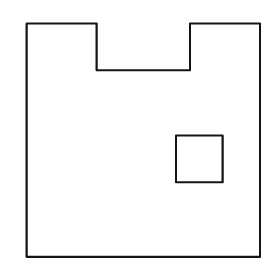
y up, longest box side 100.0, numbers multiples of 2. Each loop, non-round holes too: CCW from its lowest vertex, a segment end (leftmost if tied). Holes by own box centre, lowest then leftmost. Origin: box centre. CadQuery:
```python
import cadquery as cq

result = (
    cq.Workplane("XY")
    .moveTo(-50.0, -50.0)
    .lineTo(50.0, -50.0)
    .lineTo(50.0, 50.0)
    .lineTo(20.0, 50.0)
    .lineTo(20.0, 30.0)
    .lineTo(-20.0, 30.0)
    .lineTo(-20.0, 50.0)
    .lineTo(-50.0, 50.0)
    .close()
    .moveTo(14.0, -18.0)
    .lineTo(34.0, -18.0)
    .lineTo(34.0, 2.0)
    .lineTo(14.0, 2.0)
    .close()
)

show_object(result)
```